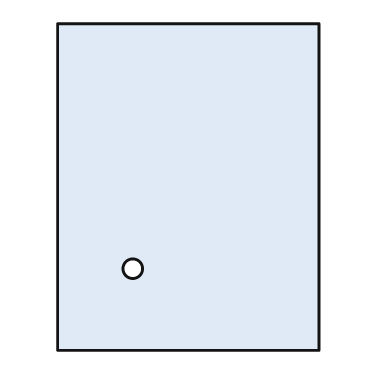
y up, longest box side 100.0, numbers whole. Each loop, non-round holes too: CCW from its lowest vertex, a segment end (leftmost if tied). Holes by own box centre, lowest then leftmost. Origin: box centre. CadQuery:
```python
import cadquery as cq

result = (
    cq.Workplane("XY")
    .moveTo(-40.0, -50.0)
    .lineTo(40.0, -50.0)
    .lineTo(40.0, 50.0)
    .lineTo(-40.0, 50.0)
    .close()
    .moveTo(-17.0, -25.0)
    .circle(3.0)
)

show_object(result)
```